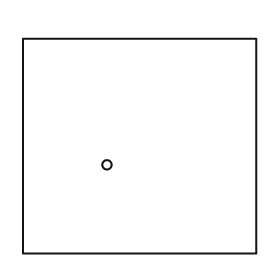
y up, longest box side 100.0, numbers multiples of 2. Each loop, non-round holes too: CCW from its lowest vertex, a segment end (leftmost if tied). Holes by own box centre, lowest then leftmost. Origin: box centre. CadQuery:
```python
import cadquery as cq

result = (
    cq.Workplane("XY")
    .moveTo(-50.0, -46.0)
    .lineTo(50.0, -46.0)
    .lineTo(50.0, 46.0)
    .lineTo(-50.0, 46.0)
    .close()
    .moveTo(-14.0, -8.0)
    .circle(2.0)
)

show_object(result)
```